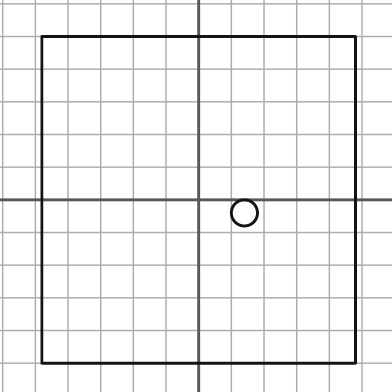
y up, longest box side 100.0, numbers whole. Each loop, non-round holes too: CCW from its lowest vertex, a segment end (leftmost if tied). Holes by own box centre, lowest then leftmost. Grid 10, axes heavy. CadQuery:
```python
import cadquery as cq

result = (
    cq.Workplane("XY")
    .moveTo(-48.0, -50.0)
    .lineTo(48.0, -50.0)
    .lineTo(48.0, 50.0)
    .lineTo(-48.0, 50.0)
    .close()
    .moveTo(14.0, -4.0)
    .circle(4.0)
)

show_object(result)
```